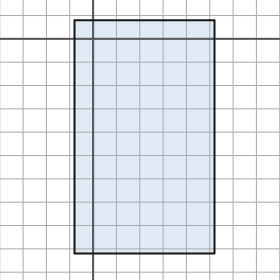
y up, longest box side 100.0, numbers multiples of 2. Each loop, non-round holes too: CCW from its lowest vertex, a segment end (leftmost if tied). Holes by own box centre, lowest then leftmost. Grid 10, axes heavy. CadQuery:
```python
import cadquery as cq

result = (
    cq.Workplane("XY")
    .moveTo(-8.0, -92.0)
    .lineTo(52.0, -92.0)
    .lineTo(52.0, 8.0)
    .lineTo(-8.0, 8.0)
    .close()
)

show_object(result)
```